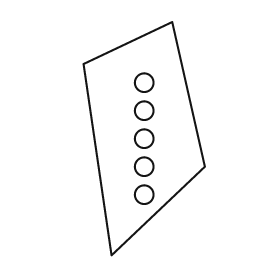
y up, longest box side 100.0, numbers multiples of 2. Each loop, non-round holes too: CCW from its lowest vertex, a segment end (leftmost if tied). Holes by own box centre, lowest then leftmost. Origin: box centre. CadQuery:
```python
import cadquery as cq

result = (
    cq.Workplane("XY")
    .moveTo(-14.0, -50.0)
    .lineTo(26.0, -12.0)
    .lineTo(12.0, 50.0)
    .lineTo(-26.0, 32.0)
    .close()
    .moveTo(0.0, -24.0)
    .circle(4.0)
    .moveTo(0.0, -12.0)
    .circle(4.0)
    .moveTo(0.0, 0.0)
    .circle(4.0)
    .moveTo(0.0, 12.0)
    .circle(4.0)
    .moveTo(0.0, 24.0)
    .circle(4.0)
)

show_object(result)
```